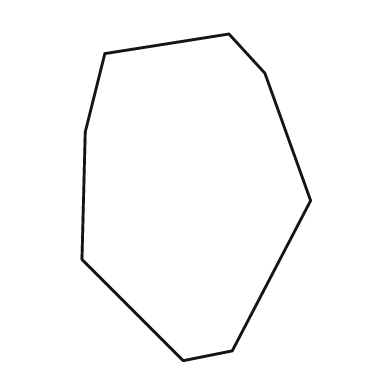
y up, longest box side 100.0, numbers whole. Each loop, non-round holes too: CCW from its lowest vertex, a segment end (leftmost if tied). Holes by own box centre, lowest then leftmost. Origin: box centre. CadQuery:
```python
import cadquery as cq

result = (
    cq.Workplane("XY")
    .moveTo(-4.0, -50.0)
    .lineTo(11.0, -47.0)
    .lineTo(35.0, -1.0)
    .lineTo(21.0, 38.0)
    .lineTo(10.0, 50.0)
    .lineTo(-28.0, 44.0)
    .lineTo(-34.0, 20.0)
    .lineTo(-35.0, -19.0)
    .close()
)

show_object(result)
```